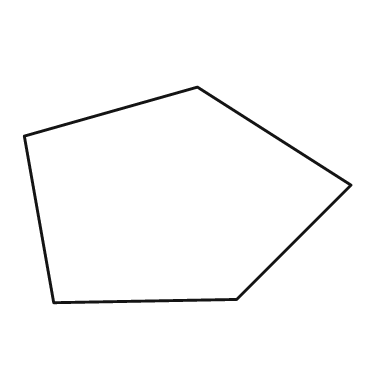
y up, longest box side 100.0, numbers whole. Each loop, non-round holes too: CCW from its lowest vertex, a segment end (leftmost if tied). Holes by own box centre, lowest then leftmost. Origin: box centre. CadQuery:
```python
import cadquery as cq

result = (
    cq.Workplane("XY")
    .moveTo(-41.0, -33.0)
    .lineTo(15.0, -32.0)
    .lineTo(50.0, 3.0)
    .lineTo(3.0, 33.0)
    .lineTo(-50.0, 18.0)
    .close()
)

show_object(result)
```